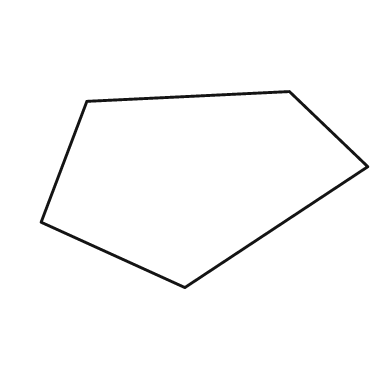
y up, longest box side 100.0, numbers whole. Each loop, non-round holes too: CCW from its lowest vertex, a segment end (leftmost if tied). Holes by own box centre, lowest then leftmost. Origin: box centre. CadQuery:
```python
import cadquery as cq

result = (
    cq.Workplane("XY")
    .moveTo(-6.0, -30.0)
    .lineTo(50.0, 7.0)
    .lineTo(26.0, 30.0)
    .lineTo(-36.0, 27.0)
    .lineTo(-50.0, -10.0)
    .close()
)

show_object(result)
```